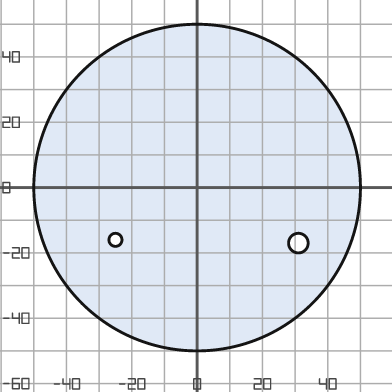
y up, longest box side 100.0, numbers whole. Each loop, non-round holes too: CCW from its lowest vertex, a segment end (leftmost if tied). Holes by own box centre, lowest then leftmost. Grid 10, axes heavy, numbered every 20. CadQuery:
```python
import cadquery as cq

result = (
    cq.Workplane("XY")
    .moveTo(0.0, 0.0)
    .circle(50.0)
    .moveTo(31.0, -17.0)
    .circle(3.0)
    .moveTo(-25.0, -16.0)
    .circle(2.0)
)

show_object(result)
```